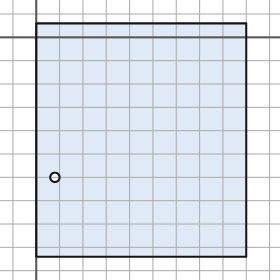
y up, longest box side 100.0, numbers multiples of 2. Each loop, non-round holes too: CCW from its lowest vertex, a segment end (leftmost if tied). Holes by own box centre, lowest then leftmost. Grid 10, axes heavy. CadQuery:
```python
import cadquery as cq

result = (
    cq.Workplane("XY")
    .moveTo(0.0, -94.0)
    .lineTo(90.0, -94.0)
    .lineTo(90.0, 6.0)
    .lineTo(0.0, 6.0)
    .close()
    .moveTo(8.0, -60.0)
    .circle(2.0)
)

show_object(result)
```